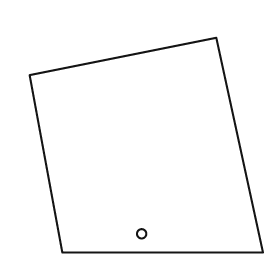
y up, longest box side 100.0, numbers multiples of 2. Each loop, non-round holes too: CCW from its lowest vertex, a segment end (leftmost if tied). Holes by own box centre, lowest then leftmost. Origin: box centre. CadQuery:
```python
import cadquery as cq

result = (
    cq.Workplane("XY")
    .moveTo(-36.0, -46.0)
    .lineTo(50.0, -46.0)
    .lineTo(30.0, 46.0)
    .lineTo(-50.0, 30.0)
    .close()
    .moveTo(-2.0, -38.0)
    .circle(2.0)
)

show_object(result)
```